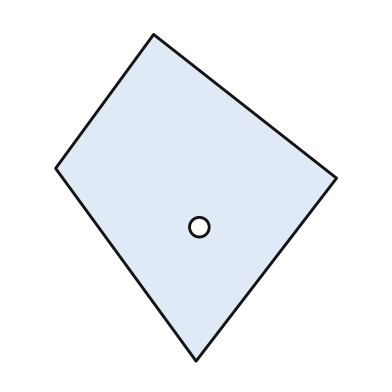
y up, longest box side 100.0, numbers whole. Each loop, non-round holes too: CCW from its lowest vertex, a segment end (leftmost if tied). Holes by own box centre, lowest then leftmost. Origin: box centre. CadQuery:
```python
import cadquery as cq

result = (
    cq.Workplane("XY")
    .moveTo(0.0, -50.0)
    .lineTo(43.0, 6.0)
    .lineTo(-13.0, 50.0)
    .lineTo(-43.0, 9.0)
    .close()
    .moveTo(1.0, -9.0)
    .circle(3.0)
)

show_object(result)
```